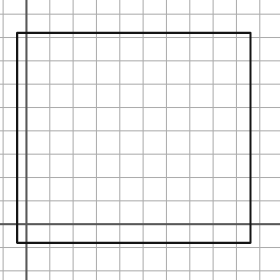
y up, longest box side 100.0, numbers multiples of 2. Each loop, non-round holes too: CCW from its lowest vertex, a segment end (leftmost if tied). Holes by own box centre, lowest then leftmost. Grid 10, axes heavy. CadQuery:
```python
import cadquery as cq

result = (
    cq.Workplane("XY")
    .moveTo(-4.0, -8.0)
    .lineTo(96.0, -8.0)
    .lineTo(96.0, 82.0)
    .lineTo(-4.0, 82.0)
    .close()
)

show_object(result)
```